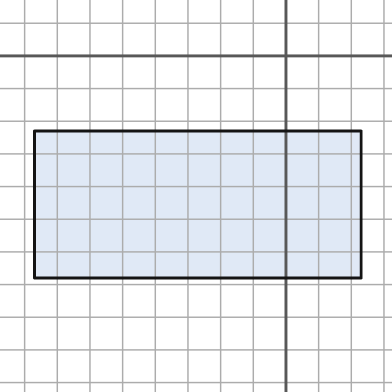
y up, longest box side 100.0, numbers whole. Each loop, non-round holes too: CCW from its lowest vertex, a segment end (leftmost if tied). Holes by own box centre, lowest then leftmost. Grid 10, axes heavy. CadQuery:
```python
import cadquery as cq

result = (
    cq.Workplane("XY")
    .moveTo(-77.0, -68.0)
    .lineTo(23.0, -68.0)
    .lineTo(23.0, -23.0)
    .lineTo(-77.0, -23.0)
    .close()
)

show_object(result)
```